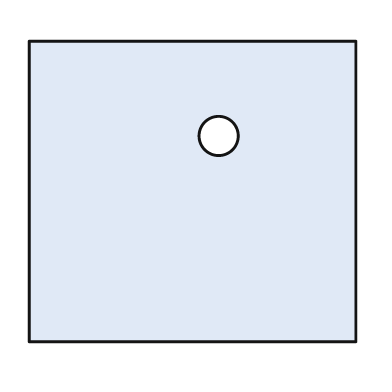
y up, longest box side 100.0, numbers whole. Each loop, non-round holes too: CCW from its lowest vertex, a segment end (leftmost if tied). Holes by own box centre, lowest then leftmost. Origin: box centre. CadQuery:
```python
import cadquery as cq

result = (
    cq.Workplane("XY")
    .moveTo(-50.0, -46.0)
    .lineTo(50.0, -46.0)
    .lineTo(50.0, 46.0)
    .lineTo(-50.0, 46.0)
    .close()
    .moveTo(8.0, 17.0)
    .circle(6.0)
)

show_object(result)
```